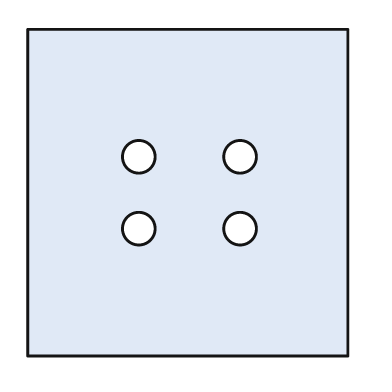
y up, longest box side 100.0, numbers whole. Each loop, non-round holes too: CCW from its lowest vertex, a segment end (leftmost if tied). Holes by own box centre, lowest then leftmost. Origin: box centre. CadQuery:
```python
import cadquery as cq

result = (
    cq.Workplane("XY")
    .moveTo(-49.0, -50.0)
    .lineTo(49.0, -50.0)
    .lineTo(49.0, 50.0)
    .lineTo(-49.0, 50.0)
    .close()
    .moveTo(-15.0, -11.0)
    .circle(5.0)
    .moveTo(16.0, -11.0)
    .circle(5.0)
    .moveTo(-15.0, 11.0)
    .circle(5.0)
    .moveTo(16.0, 11.0)
    .circle(5.0)
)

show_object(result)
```